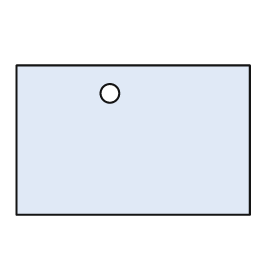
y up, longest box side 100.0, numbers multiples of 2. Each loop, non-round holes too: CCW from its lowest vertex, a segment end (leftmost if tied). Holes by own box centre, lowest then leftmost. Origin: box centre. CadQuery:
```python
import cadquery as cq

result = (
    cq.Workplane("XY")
    .moveTo(-50.0, -32.0)
    .lineTo(50.0, -32.0)
    .lineTo(50.0, 32.0)
    .lineTo(-50.0, 32.0)
    .close()
    .moveTo(-10.0, 20.0)
    .circle(4.0)
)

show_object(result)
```